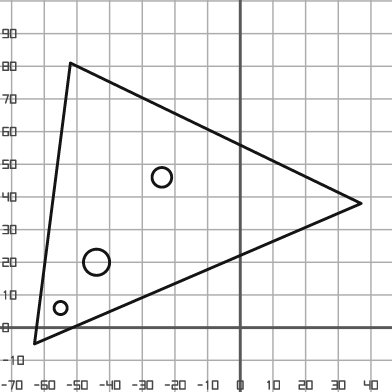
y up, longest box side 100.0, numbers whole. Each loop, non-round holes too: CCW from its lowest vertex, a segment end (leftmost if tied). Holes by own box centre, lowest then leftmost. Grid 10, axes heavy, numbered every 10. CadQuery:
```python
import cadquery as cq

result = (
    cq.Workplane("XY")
    .moveTo(-63.0, -5.0)
    .lineTo(37.0, 38.0)
    .lineTo(-52.0, 81.0)
    .close()
    .moveTo(-55.0, 6.0)
    .circle(2.0)
    .moveTo(-44.0, 20.0)
    .circle(4.0)
    .moveTo(-24.0, 46.0)
    .circle(3.0)
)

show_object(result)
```